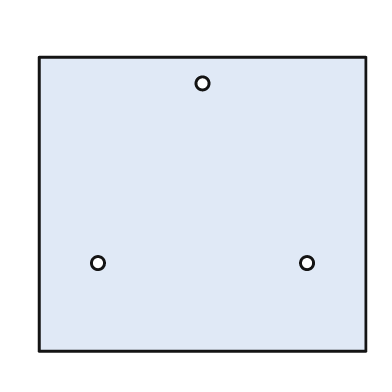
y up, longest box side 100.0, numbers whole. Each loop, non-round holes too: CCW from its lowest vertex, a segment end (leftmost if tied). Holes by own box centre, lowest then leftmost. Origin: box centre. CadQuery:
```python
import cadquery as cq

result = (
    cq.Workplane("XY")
    .moveTo(-50.0, -45.0)
    .lineTo(50.0, -45.0)
    .lineTo(50.0, 45.0)
    .lineTo(-50.0, 45.0)
    .close()
    .moveTo(-32.0, -18.0)
    .circle(2.0)
    .moveTo(32.0, -18.0)
    .circle(2.0)
    .moveTo(0.0, 37.0)
    .circle(2.0)
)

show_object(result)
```